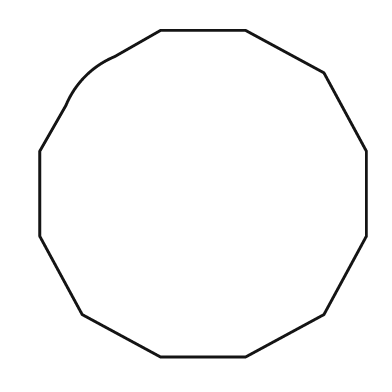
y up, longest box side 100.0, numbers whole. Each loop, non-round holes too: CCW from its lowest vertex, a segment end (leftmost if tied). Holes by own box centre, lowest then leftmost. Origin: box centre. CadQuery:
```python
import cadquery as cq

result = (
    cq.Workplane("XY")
    .moveTo(-13.0, -50.0)
    .lineTo(13.0, -50.0)
    .lineTo(37.0, -37.0)
    .lineTo(50.0, -13.0)
    .lineTo(50.0, 13.0)
    .lineTo(37.0, 37.0)
    .lineTo(13.0, 50.0)
    .lineTo(-13.0, 50.0)
    .lineTo(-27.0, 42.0)
    .threePointArc((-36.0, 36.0), (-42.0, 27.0))
    .lineTo(-50.0, 13.0)
    .lineTo(-50.0, -13.0)
    .lineTo(-37.0, -37.0)
    .close()
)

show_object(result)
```